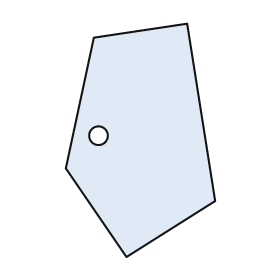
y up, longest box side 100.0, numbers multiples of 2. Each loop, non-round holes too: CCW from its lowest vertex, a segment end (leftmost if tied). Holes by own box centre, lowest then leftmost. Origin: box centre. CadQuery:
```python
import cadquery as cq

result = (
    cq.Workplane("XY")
    .moveTo(-6.0, -50.0)
    .lineTo(32.0, -26.0)
    .lineTo(20.0, 50.0)
    .lineTo(-20.0, 44.0)
    .lineTo(-32.0, -12.0)
    .close()
    .moveTo(-18.0, 2.0)
    .circle(4.0)
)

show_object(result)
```